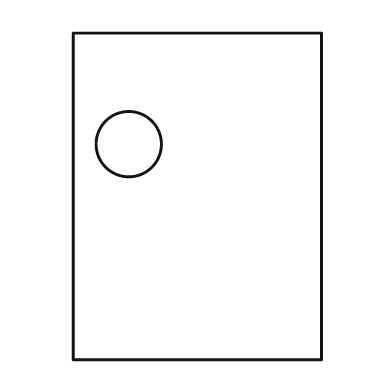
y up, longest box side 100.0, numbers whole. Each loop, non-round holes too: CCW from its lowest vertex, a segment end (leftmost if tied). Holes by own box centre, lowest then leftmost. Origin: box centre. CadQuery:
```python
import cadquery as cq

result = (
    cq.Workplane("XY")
    .moveTo(-38.0, -50.0)
    .lineTo(38.0, -50.0)
    .lineTo(38.0, 50.0)
    .lineTo(-38.0, 50.0)
    .close()
    .moveTo(-21.0, 16.0)
    .circle(10.0)
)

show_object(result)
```